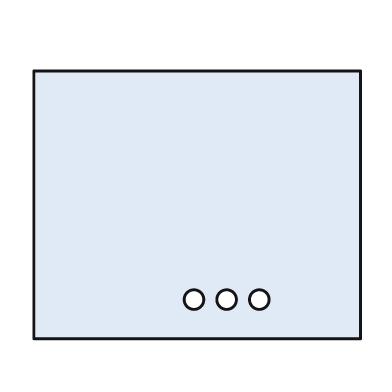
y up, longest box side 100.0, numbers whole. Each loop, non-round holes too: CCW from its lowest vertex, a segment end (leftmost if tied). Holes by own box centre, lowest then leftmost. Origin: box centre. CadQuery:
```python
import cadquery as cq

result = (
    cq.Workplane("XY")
    .moveTo(-50.0, -41.0)
    .lineTo(50.0, -41.0)
    .lineTo(50.0, 41.0)
    .lineTo(-50.0, 41.0)
    .close()
    .moveTo(-1.0, -29.0)
    .circle(3.0)
    .moveTo(9.0, -29.0)
    .circle(3.0)
    .moveTo(19.0, -29.0)
    .circle(3.0)
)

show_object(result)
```